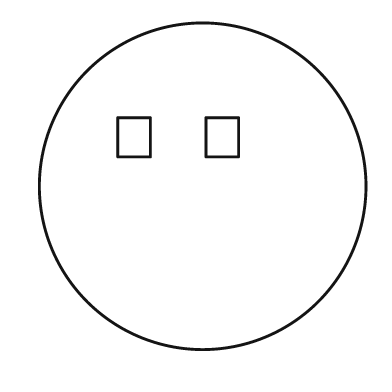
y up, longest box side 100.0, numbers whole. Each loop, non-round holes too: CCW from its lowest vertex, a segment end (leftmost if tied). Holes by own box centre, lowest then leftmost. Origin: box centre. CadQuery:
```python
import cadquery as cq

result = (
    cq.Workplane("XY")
    .moveTo(0.0, 0.0)
    .circle(50.0)
    .moveTo(-26.0, 9.0)
    .lineTo(-16.0, 9.0)
    .lineTo(-16.0, 21.0)
    .lineTo(-26.0, 21.0)
    .close()
    .moveTo(1.0, 9.0)
    .lineTo(11.0, 9.0)
    .lineTo(11.0, 21.0)
    .lineTo(1.0, 21.0)
    .close()
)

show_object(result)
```